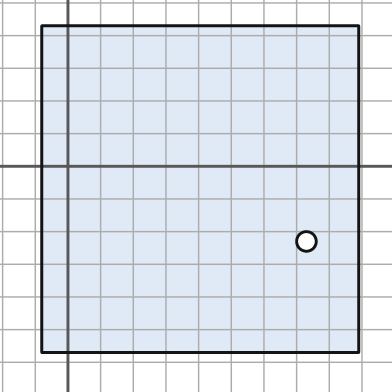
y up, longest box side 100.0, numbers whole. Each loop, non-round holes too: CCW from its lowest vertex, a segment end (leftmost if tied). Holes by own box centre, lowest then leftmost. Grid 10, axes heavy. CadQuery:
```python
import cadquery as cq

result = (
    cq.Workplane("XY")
    .moveTo(-8.0, -57.0)
    .lineTo(89.0, -57.0)
    .lineTo(89.0, 43.0)
    .lineTo(-8.0, 43.0)
    .close()
    .moveTo(73.0, -23.0)
    .circle(3.0)
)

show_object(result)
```